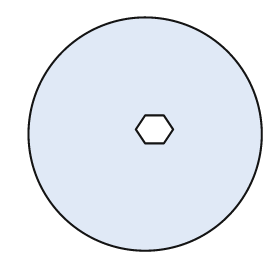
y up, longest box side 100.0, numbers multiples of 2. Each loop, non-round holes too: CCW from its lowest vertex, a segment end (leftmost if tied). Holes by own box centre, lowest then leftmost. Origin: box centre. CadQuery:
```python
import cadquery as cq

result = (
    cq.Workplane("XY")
    .moveTo(0.0, 0.0)
    .circle(50.0)
    .moveTo(0.0, -4.0)
    .lineTo(8.0, -4.0)
    .lineTo(12.0, 2.0)
    .lineTo(8.0, 8.0)
    .lineTo(0.0, 8.0)
    .lineTo(-4.0, 2.0)
    .close()
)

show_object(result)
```